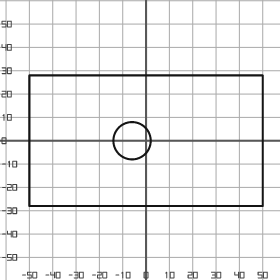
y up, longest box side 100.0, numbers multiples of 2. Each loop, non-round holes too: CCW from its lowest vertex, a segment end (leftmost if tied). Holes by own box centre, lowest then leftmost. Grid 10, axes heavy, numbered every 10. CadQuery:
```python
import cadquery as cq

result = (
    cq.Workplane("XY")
    .moveTo(-50.0, -28.0)
    .lineTo(50.0, -28.0)
    .lineTo(50.0, 28.0)
    .lineTo(-50.0, 28.0)
    .close()
    .moveTo(-6.0, 0.0)
    .circle(8.0)
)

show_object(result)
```